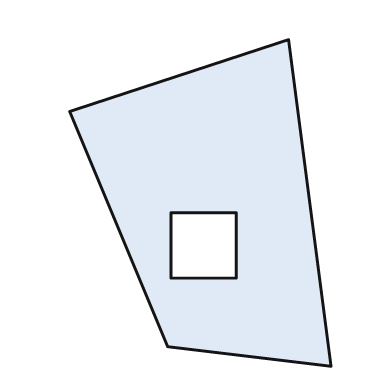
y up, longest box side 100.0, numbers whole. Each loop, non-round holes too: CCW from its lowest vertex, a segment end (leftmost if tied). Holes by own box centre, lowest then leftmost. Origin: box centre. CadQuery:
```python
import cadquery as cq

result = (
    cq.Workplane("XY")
    .moveTo(40.0, -50.0)
    .lineTo(27.0, 50.0)
    .lineTo(-40.0, 28.0)
    .lineTo(-10.0, -44.0)
    .close()
    .moveTo(-9.0, -23.0)
    .lineTo(11.0, -23.0)
    .lineTo(11.0, -3.0)
    .lineTo(-9.0, -3.0)
    .close()
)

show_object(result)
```